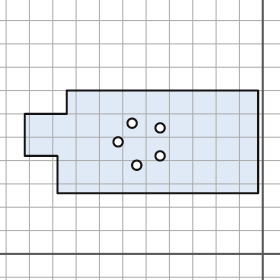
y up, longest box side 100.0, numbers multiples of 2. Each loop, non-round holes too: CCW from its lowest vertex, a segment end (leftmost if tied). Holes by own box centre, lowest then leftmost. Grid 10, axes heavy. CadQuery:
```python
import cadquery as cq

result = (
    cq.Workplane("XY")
    .moveTo(-88.0, 26.0)
    .lineTo(-2.0, 26.0)
    .lineTo(-2.0, 70.0)
    .lineTo(-84.0, 70.0)
    .lineTo(-84.0, 60.0)
    .lineTo(-102.0, 60.0)
    .lineTo(-102.0, 42.0)
    .lineTo(-88.0, 42.0)
    .close()
    .moveTo(-54.0, 38.0)
    .circle(2.0)
    .moveTo(-44.0, 42.0)
    .circle(2.0)
    .moveTo(-62.0, 48.0)
    .circle(2.0)
    .moveTo(-44.0, 54.0)
    .circle(2.0)
    .moveTo(-56.0, 56.0)
    .circle(2.0)
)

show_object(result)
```